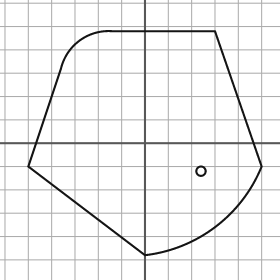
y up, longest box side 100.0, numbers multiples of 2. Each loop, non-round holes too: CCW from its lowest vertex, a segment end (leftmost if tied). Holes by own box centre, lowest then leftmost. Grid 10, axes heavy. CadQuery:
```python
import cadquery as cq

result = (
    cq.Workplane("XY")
    .moveTo(0.0, -48.0)
    .threePointArc((30.0, -36.0), (50.0, -10.0))
    .lineTo(30.0, 48.0)
    .lineTo(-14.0, 48.0)
    .threePointArc((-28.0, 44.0), (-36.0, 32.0))
    .lineTo(-50.0, -10.0)
    .close()
    .moveTo(24.0, -12.0)
    .circle(2.0)
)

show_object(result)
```